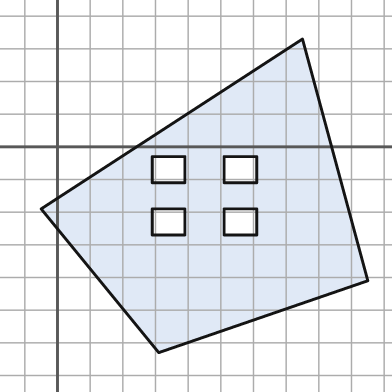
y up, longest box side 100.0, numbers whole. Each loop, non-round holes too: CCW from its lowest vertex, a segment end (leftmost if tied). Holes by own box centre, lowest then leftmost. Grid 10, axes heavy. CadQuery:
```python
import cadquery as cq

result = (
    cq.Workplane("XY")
    .moveTo(31.0, -63.0)
    .lineTo(95.0, -41.0)
    .lineTo(75.0, 33.0)
    .lineTo(-5.0, -19.0)
    .close()
    .moveTo(29.0, -27.0)
    .lineTo(39.0, -27.0)
    .lineTo(39.0, -19.0)
    .lineTo(29.0, -19.0)
    .close()
    .moveTo(51.0, -27.0)
    .lineTo(61.0, -27.0)
    .lineTo(61.0, -19.0)
    .lineTo(51.0, -19.0)
    .close()
    .moveTo(29.0, -11.0)
    .lineTo(39.0, -11.0)
    .lineTo(39.0, -3.0)
    .lineTo(29.0, -3.0)
    .close()
    .moveTo(51.0, -11.0)
    .lineTo(61.0, -11.0)
    .lineTo(61.0, -3.0)
    .lineTo(51.0, -3.0)
    .close()
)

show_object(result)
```